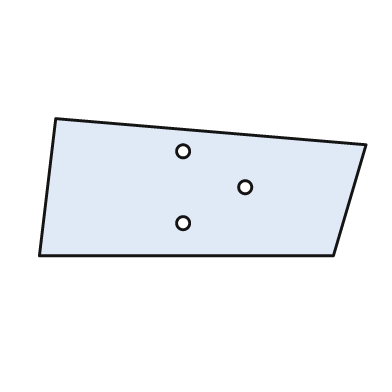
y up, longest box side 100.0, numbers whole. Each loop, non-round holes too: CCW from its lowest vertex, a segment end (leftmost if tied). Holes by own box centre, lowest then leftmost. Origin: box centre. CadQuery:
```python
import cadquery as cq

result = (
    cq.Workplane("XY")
    .moveTo(-50.0, -21.0)
    .lineTo(40.0, -21.0)
    .lineTo(50.0, 13.0)
    .lineTo(-45.0, 21.0)
    .close()
    .moveTo(-6.0, -11.0)
    .circle(2.0)
    .moveTo(13.0, 0.0)
    .circle(2.0)
    .moveTo(-6.0, 11.0)
    .circle(2.0)
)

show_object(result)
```